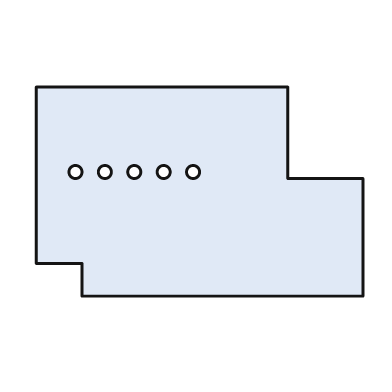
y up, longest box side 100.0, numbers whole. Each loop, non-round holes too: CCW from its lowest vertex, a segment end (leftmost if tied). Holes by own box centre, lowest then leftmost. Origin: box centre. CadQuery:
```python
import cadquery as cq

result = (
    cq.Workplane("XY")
    .moveTo(-36.0, -32.0)
    .lineTo(50.0, -32.0)
    .lineTo(50.0, 4.0)
    .lineTo(27.0, 4.0)
    .lineTo(27.0, 32.0)
    .lineTo(-50.0, 32.0)
    .lineTo(-50.0, -22.0)
    .lineTo(-36.0, -22.0)
    .close()
    .moveTo(-38.0, 6.0)
    .circle(2.0)
    .moveTo(-29.0, 6.0)
    .circle(2.0)
    .moveTo(-20.0, 6.0)
    .circle(2.0)
    .moveTo(-11.0, 6.0)
    .circle(2.0)
    .moveTo(-2.0, 6.0)
    .circle(2.0)
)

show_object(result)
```